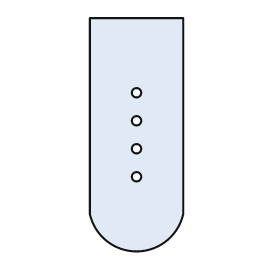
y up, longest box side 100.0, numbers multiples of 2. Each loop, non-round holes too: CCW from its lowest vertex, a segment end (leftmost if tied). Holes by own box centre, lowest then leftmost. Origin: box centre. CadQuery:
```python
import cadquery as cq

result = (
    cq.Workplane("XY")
    .moveTo(-20.0, -34.0)
    .threePointArc((0.0, -50.0), (20.0, -34.0))
    .lineTo(20.0, 50.0)
    .lineTo(-20.0, 50.0)
    .close()
    .moveTo(0.0, -18.0)
    .circle(2.0)
    .moveTo(0.0, -6.0)
    .circle(2.0)
    .moveTo(0.0, 6.0)
    .circle(2.0)
    .moveTo(0.0, 18.0)
    .circle(2.0)
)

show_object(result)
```